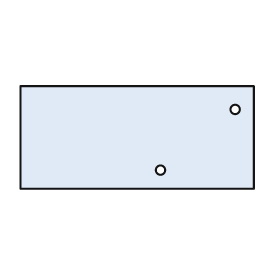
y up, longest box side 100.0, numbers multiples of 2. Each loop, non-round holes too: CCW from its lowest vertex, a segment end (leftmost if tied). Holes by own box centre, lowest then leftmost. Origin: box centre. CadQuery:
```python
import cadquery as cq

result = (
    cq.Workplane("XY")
    .moveTo(-50.0, -22.0)
    .lineTo(50.0, -22.0)
    .lineTo(50.0, 22.0)
    .lineTo(-50.0, 22.0)
    .close()
    .moveTo(10.0, -14.0)
    .circle(2.0)
    .moveTo(42.0, 12.0)
    .circle(2.0)
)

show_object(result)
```